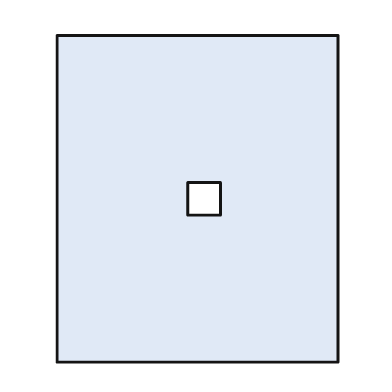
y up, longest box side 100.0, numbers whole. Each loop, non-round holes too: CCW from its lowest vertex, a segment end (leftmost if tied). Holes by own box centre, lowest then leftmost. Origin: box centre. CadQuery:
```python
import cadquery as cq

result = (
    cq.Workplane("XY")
    .moveTo(-43.0, -50.0)
    .lineTo(43.0, -50.0)
    .lineTo(43.0, 50.0)
    .lineTo(-43.0, 50.0)
    .close()
    .moveTo(-3.0, -5.0)
    .lineTo(7.0, -5.0)
    .lineTo(7.0, 5.0)
    .lineTo(-3.0, 5.0)
    .close()
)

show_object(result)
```